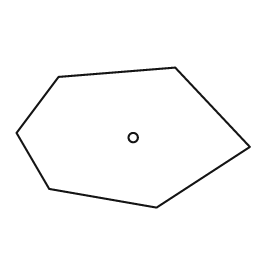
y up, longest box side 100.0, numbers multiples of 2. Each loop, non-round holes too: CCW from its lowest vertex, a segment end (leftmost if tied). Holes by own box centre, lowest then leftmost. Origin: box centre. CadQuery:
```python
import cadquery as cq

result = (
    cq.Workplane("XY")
    .moveTo(10.0, -30.0)
    .lineTo(50.0, -4.0)
    .lineTo(18.0, 30.0)
    .lineTo(-32.0, 26.0)
    .lineTo(-50.0, 2.0)
    .lineTo(-36.0, -22.0)
    .close()
    .moveTo(0.0, 0.0)
    .circle(2.0)
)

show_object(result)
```